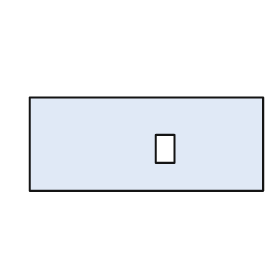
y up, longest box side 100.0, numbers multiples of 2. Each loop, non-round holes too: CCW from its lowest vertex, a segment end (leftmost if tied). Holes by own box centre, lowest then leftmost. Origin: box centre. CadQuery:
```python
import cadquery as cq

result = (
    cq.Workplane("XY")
    .moveTo(-50.0, -20.0)
    .lineTo(50.0, -20.0)
    .lineTo(50.0, 20.0)
    .lineTo(-50.0, 20.0)
    .close()
    .moveTo(4.0, -8.0)
    .lineTo(12.0, -8.0)
    .lineTo(12.0, 4.0)
    .lineTo(4.0, 4.0)
    .close()
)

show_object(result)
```